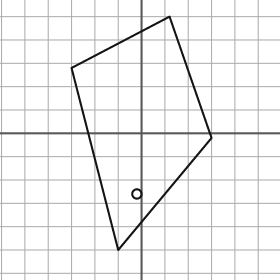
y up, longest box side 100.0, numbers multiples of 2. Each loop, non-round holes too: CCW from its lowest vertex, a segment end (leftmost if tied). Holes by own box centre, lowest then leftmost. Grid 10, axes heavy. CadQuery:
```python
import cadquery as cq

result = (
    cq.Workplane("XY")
    .moveTo(-10.0, -50.0)
    .lineTo(30.0, -2.0)
    .lineTo(12.0, 50.0)
    .lineTo(-30.0, 28.0)
    .close()
    .moveTo(-2.0, -26.0)
    .circle(2.0)
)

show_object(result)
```